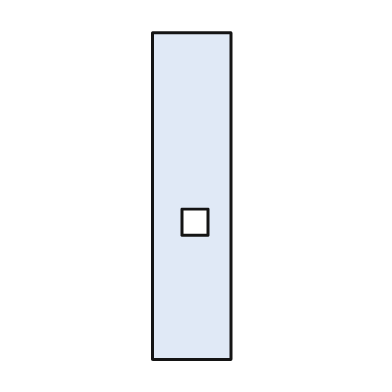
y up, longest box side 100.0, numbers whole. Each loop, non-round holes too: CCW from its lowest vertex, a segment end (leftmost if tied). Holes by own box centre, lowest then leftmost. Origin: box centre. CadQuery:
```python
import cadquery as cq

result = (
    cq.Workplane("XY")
    .moveTo(-12.0, -50.0)
    .lineTo(12.0, -50.0)
    .lineTo(12.0, 50.0)
    .lineTo(-12.0, 50.0)
    .close()
    .moveTo(-3.0, -12.0)
    .lineTo(5.0, -12.0)
    .lineTo(5.0, -4.0)
    .lineTo(-3.0, -4.0)
    .close()
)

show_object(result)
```